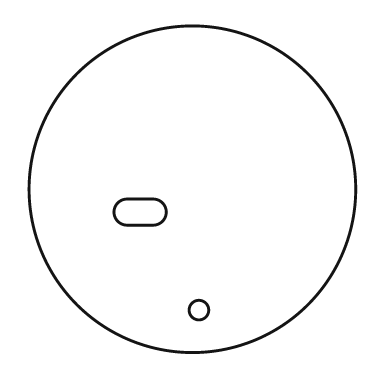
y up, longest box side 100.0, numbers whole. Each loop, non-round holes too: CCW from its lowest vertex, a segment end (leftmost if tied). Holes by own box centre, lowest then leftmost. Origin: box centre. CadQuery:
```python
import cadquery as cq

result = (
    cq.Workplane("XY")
    .moveTo(0.0, 0.0)
    .circle(50.0)
    .moveTo(2.0, -37.0)
    .circle(3.0)
    .moveTo(-20.0, -11.0)
    .lineTo(-12.0, -11.0)
    .threePointArc((-8.0, -7.0), (-12.0, -3.0))
    .lineTo(-20.0, -3.0)
    .threePointArc((-24.0, -7.0), (-20.0, -11.0))
    .close()
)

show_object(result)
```